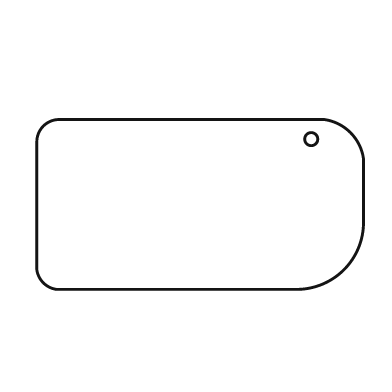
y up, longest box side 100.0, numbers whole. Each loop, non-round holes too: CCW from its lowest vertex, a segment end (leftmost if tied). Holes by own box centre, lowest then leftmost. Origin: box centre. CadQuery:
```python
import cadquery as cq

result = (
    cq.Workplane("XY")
    .moveTo(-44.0, -26.0)
    .lineTo(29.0, -26.0)
    .threePointArc((44.0, -20.0), (50.0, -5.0))
    .lineTo(50.0, 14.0)
    .threePointArc((46.0, 22.0), (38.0, 26.0))
    .lineTo(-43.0, 26.0)
    .threePointArc((-48.0, 24.0), (-50.0, 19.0))
    .lineTo(-50.0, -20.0)
    .threePointArc((-48.0, -24.0), (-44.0, -26.0))
    .close()
    .moveTo(34.0, 20.0)
    .circle(2.0)
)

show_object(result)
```